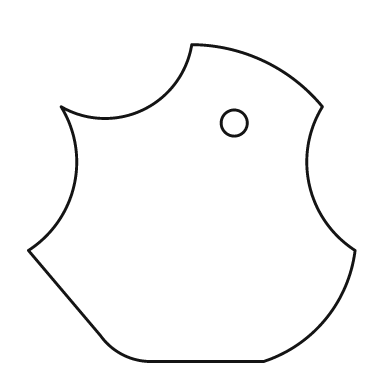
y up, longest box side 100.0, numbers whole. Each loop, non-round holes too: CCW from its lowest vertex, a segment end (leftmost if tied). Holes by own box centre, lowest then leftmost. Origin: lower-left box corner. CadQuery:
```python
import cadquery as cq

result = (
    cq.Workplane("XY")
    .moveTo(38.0, 0.0)
    .lineTo(72.0, 0.0)
    .threePointArc((91.0, 13.0), (100.0, 34.0))
    .threePointArc((86.0, 54.0), (90.0, 78.0))
    .threePointArc((72.0, 92.0), (50.0, 97.0))
    .threePointArc((35.0, 77.0), (10.0, 78.0))
    .threePointArc((14.0, 54.0), (0.0, 34.0))
    .lineTo(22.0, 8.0)
    .threePointArc((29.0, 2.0), (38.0, 0.0))
    .close()
    .moveTo(63.0, 73.0)
    .circle(4.0)
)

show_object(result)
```